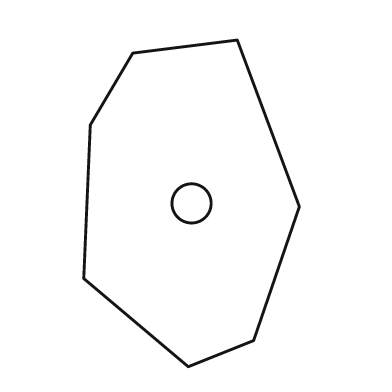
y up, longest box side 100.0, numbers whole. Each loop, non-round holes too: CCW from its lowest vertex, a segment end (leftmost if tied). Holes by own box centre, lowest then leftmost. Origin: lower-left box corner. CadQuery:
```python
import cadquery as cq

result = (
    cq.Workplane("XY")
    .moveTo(32.0, 0.0)
    .lineTo(52.0, 8.0)
    .lineTo(66.0, 49.0)
    .lineTo(47.0, 100.0)
    .lineTo(15.0, 96.0)
    .lineTo(2.0, 74.0)
    .lineTo(0.0, 27.0)
    .close()
    .moveTo(33.0, 50.0)
    .circle(6.0)
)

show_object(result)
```